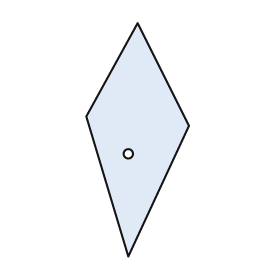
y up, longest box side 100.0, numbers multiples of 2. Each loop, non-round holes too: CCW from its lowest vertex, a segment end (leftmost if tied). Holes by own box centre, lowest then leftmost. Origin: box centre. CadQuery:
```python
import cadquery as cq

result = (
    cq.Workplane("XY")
    .moveTo(-4.0, -50.0)
    .lineTo(22.0, 6.0)
    .lineTo(0.0, 50.0)
    .lineTo(-22.0, 10.0)
    .close()
    .moveTo(-4.0, -6.0)
    .circle(2.0)
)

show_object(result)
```